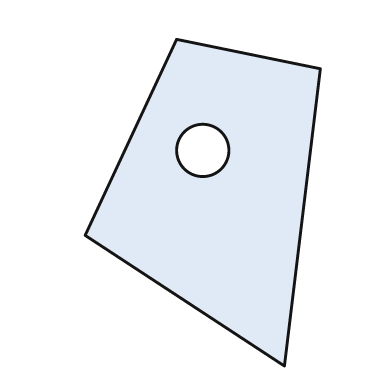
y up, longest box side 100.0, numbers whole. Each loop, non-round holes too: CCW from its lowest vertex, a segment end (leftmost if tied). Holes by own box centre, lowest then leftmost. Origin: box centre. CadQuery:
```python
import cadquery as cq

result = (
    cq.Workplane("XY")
    .moveTo(25.0, -50.0)
    .lineTo(36.0, 41.0)
    .lineTo(-8.0, 50.0)
    .lineTo(-36.0, -10.0)
    .close()
    .moveTo(0.0, 16.0)
    .circle(8.0)
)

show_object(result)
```